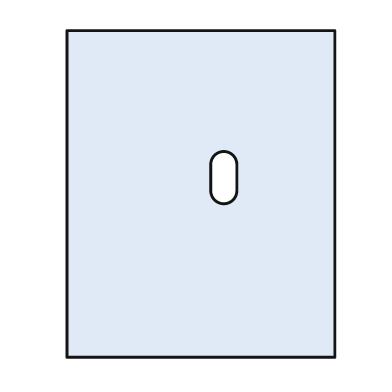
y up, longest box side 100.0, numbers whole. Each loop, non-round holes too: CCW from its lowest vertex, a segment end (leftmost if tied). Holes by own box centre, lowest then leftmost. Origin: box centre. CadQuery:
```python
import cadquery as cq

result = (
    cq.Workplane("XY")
    .moveTo(-41.0, -50.0)
    .lineTo(41.0, -50.0)
    .lineTo(41.0, 50.0)
    .lineTo(-41.0, 50.0)
    .close()
    .moveTo(3.0, 1.0)
    .threePointArc((7.0, -3.0), (11.0, 1.0))
    .lineTo(11.0, 9.0)
    .threePointArc((7.0, 13.0), (3.0, 9.0))
    .close()
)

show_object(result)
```